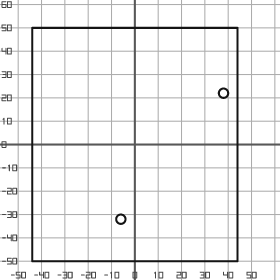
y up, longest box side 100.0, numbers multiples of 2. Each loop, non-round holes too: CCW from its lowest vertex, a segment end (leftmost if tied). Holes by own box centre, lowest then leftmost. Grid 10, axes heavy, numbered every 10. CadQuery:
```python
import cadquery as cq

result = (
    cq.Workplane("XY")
    .moveTo(-44.0, -50.0)
    .lineTo(44.0, -50.0)
    .lineTo(44.0, 50.0)
    .lineTo(-44.0, 50.0)
    .close()
    .moveTo(-6.0, -32.0)
    .circle(2.0)
    .moveTo(38.0, 22.0)
    .circle(2.0)
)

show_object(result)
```